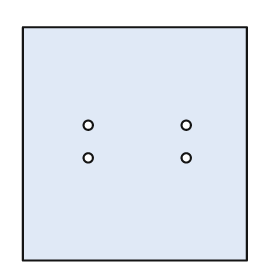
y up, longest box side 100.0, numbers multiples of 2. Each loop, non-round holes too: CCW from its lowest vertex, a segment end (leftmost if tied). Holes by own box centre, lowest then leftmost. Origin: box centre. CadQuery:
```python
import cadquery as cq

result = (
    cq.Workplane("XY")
    .moveTo(-48.0, -50.0)
    .lineTo(48.0, -50.0)
    .lineTo(48.0, 50.0)
    .lineTo(-48.0, 50.0)
    .close()
    .moveTo(-20.0, -6.0)
    .circle(2.0)
    .moveTo(22.0, -6.0)
    .circle(2.0)
    .moveTo(-20.0, 8.0)
    .circle(2.0)
    .moveTo(22.0, 8.0)
    .circle(2.0)
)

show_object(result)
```